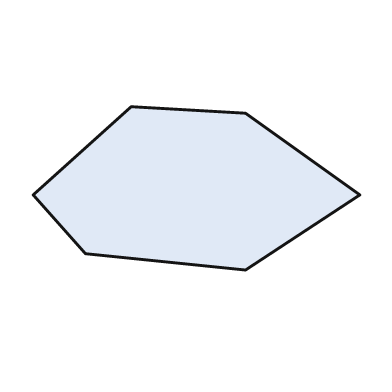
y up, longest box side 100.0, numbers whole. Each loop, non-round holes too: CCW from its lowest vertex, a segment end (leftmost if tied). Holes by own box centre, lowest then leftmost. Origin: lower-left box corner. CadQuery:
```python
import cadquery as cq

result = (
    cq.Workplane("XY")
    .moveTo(65.0, 0.0)
    .lineTo(100.0, 23.0)
    .lineTo(65.0, 48.0)
    .lineTo(30.0, 50.0)
    .lineTo(0.0, 23.0)
    .lineTo(16.0, 5.0)
    .close()
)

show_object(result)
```